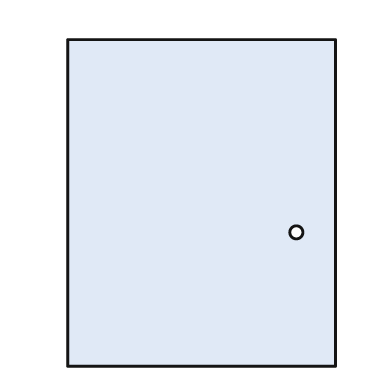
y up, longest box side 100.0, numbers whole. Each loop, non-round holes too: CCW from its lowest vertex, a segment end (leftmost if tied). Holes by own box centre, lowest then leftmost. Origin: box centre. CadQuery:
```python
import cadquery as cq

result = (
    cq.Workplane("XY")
    .moveTo(-41.0, -50.0)
    .lineTo(41.0, -50.0)
    .lineTo(41.0, 50.0)
    .lineTo(-41.0, 50.0)
    .close()
    .moveTo(29.0, -9.0)
    .circle(2.0)
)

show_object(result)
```